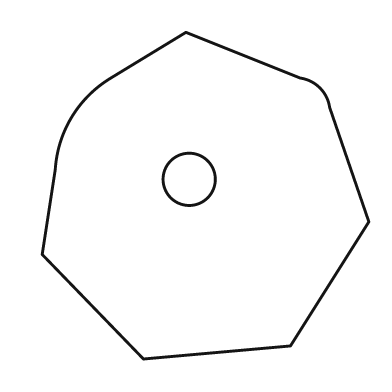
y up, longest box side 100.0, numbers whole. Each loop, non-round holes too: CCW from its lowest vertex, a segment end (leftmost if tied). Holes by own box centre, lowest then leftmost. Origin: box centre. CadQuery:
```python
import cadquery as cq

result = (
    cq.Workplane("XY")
    .moveTo(-19.0, -50.0)
    .lineTo(26.0, -46.0)
    .lineTo(50.0, -8.0)
    .lineTo(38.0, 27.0)
    .threePointArc((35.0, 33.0), (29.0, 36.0))
    .lineTo(-6.0, 50.0)
    .lineTo(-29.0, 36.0)
    .threePointArc((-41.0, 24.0), (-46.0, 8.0))
    .lineTo(-50.0, -18.0)
    .close()
    .moveTo(-5.0, 5.0)
    .circle(8.0)
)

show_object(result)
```